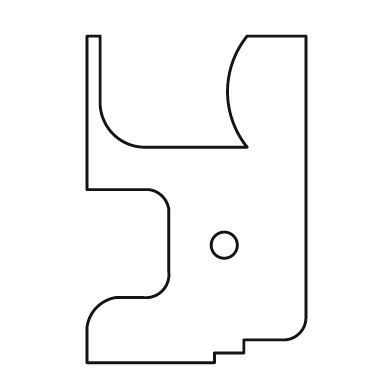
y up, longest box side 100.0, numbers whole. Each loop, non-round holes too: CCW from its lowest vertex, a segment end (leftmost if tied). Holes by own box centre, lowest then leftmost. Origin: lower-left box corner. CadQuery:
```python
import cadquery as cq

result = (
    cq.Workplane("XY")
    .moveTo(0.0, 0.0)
    .lineTo(39.0, 0.0)
    .lineTo(39.0, 3.0)
    .lineTo(48.0, 3.0)
    .lineTo(48.0, 7.0)
    .lineTo(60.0, 7.0)
    .threePointArc((65.0, 9.0), (67.0, 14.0))
    .lineTo(67.0, 100.0)
    .lineTo(49.0, 100.0)
    .threePointArc((43.0, 83.0), (49.0, 66.0))
    .lineTo(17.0, 66.0)
    .threePointArc((8.0, 70.0), (4.0, 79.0))
    .lineTo(4.0, 100.0)
    .lineTo(0.0, 100.0)
    .lineTo(0.0, 53.0)
    .lineTo(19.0, 53.0)
    .threePointArc((23.0, 51.0), (25.0, 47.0))
    .lineTo(25.0, 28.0)
    .threePointArc((23.0, 22.0), (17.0, 20.0))
    .lineTo(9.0, 20.0)
    .threePointArc((3.0, 17.0), (0.0, 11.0))
    .close()
    .moveTo(42.0, 36.0)
    .circle(4.0)
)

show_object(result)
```